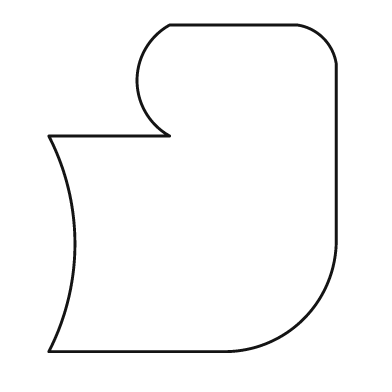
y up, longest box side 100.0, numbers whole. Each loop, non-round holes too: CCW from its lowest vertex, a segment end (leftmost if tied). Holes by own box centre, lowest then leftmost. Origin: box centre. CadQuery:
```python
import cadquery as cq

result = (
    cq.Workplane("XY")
    .moveTo(-44.0, -50.0)
    .lineTo(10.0, -50.0)
    .threePointArc((34.0, -40.0), (44.0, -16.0))
    .lineTo(44.0, 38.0)
    .threePointArc((40.0, 46.0), (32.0, 50.0))
    .lineTo(-7.0, 50.0)
    .threePointArc((-17.0, 33.0), (-7.0, 16.0))
    .lineTo(-44.0, 16.0)
    .threePointArc((-36.0, -17.0), (-44.0, -50.0))
    .close()
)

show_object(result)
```